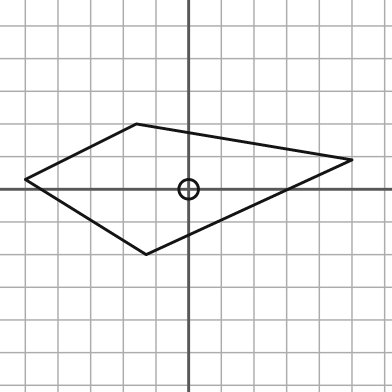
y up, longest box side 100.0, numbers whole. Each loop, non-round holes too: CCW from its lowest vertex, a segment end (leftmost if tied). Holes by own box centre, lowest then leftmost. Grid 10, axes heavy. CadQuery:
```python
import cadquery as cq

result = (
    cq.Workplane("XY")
    .moveTo(-13.0, -20.0)
    .lineTo(50.0, 9.0)
    .lineTo(-16.0, 20.0)
    .lineTo(-50.0, 3.0)
    .close()
    .moveTo(0.0, 0.0)
    .circle(3.0)
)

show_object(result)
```